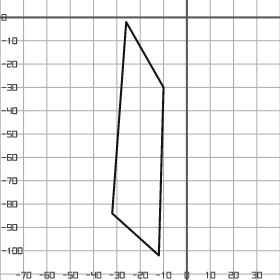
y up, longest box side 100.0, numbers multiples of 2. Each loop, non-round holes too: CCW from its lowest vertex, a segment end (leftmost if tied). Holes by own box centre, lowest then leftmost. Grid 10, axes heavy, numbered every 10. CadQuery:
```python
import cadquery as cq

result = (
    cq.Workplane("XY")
    .moveTo(-12.0, -102.0)
    .lineTo(-10.0, -30.0)
    .lineTo(-26.0, -2.0)
    .lineTo(-32.0, -84.0)
    .close()
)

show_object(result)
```